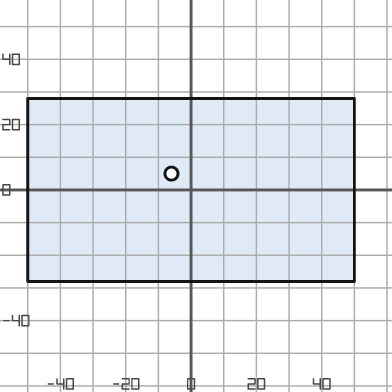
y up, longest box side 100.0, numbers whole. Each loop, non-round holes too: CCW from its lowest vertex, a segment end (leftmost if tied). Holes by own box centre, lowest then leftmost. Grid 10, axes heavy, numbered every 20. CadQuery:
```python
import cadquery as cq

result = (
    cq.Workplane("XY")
    .moveTo(-50.0, -28.0)
    .lineTo(50.0, -28.0)
    .lineTo(50.0, 28.0)
    .lineTo(-50.0, 28.0)
    .close()
    .moveTo(-6.0, 5.0)
    .circle(2.0)
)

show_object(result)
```